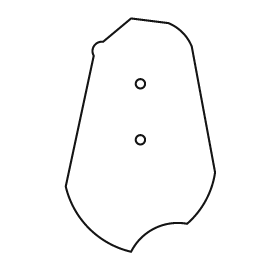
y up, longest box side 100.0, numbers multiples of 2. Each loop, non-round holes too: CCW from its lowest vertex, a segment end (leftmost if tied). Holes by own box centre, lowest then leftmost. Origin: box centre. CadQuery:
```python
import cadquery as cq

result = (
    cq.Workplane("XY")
    .moveTo(-4.0, -50.0)
    .threePointArc((6.0, -40.0), (20.0, -38.0))
    .threePointArc((28.0, -28.0), (32.0, -16.0))
    .lineTo(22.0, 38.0)
    .threePointArc((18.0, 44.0), (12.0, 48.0))
    .lineTo(-4.0, 50.0)
    .lineTo(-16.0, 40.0)
    .threePointArc((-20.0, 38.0), (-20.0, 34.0))
    .lineTo(-32.0, -22.0)
    .threePointArc((-22.0, -40.0), (-4.0, -50.0))
    .close()
    .moveTo(0.0, -2.0)
    .circle(2.0)
    .moveTo(0.0, 22.0)
    .circle(2.0)
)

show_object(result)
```